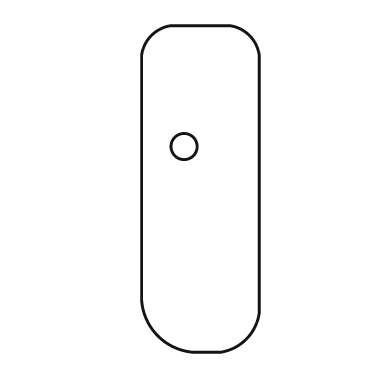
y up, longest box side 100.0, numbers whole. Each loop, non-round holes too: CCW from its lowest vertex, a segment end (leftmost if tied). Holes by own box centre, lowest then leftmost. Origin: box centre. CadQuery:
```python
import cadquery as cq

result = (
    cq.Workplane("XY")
    .moveTo(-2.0, -50.0)
    .lineTo(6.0, -50.0)
    .threePointArc((14.0, -46.0), (18.0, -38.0))
    .lineTo(18.0, 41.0)
    .threePointArc((15.0, 47.0), (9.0, 50.0))
    .lineTo(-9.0, 50.0)
    .threePointArc((-15.0, 47.0), (-18.0, 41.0))
    .lineTo(-18.0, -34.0)
    .threePointArc((-13.0, -45.0), (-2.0, -50.0))
    .close()
    .moveTo(-5.0, 13.0)
    .circle(4.0)
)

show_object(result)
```